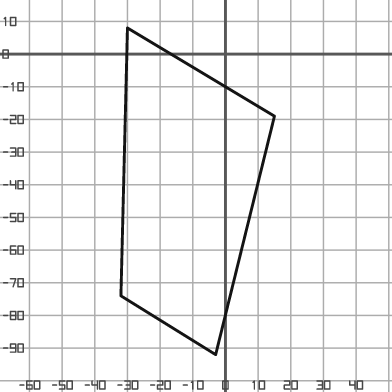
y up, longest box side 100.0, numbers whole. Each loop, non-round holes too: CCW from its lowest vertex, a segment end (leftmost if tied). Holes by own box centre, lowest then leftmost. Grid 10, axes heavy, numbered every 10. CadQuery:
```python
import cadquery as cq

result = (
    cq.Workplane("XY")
    .moveTo(-3.0, -92.0)
    .lineTo(15.0, -19.0)
    .lineTo(-30.0, 8.0)
    .lineTo(-32.0, -74.0)
    .close()
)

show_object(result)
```